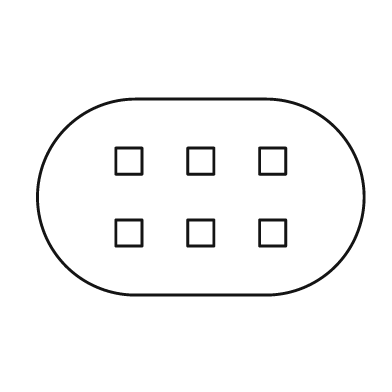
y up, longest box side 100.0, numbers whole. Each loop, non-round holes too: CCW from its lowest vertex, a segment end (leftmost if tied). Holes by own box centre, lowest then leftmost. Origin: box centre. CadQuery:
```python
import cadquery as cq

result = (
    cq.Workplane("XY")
    .moveTo(-20.0, -30.0)
    .lineTo(20.0, -30.0)
    .threePointArc((50.0, 0.0), (20.0, 30.0))
    .lineTo(-20.0, 30.0)
    .threePointArc((-50.0, 0.0), (-20.0, -30.0))
    .close()
    .moveTo(-26.0, -15.0)
    .lineTo(-18.0, -15.0)
    .lineTo(-18.0, -7.0)
    .lineTo(-26.0, -7.0)
    .close()
    .moveTo(-4.0, -15.0)
    .lineTo(4.0, -15.0)
    .lineTo(4.0, -7.0)
    .lineTo(-4.0, -7.0)
    .close()
    .moveTo(18.0, -15.0)
    .lineTo(26.0, -15.0)
    .lineTo(26.0, -7.0)
    .lineTo(18.0, -7.0)
    .close()
    .moveTo(-26.0, 7.0)
    .lineTo(-18.0, 7.0)
    .lineTo(-18.0, 15.0)
    .lineTo(-26.0, 15.0)
    .close()
    .moveTo(-4.0, 7.0)
    .lineTo(4.0, 7.0)
    .lineTo(4.0, 15.0)
    .lineTo(-4.0, 15.0)
    .close()
    .moveTo(18.0, 7.0)
    .lineTo(26.0, 7.0)
    .lineTo(26.0, 15.0)
    .lineTo(18.0, 15.0)
    .close()
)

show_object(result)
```